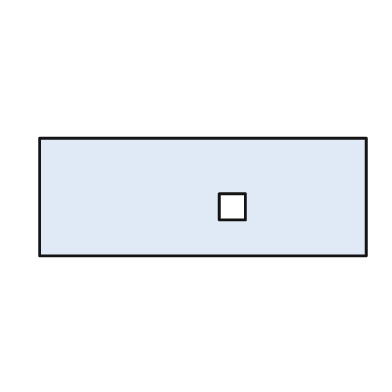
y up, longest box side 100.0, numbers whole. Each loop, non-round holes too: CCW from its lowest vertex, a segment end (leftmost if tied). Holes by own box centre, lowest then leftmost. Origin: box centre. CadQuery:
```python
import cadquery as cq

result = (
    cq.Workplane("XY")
    .moveTo(-50.0, -18.0)
    .lineTo(50.0, -18.0)
    .lineTo(50.0, 18.0)
    .lineTo(-50.0, 18.0)
    .close()
    .moveTo(5.0, -7.0)
    .lineTo(13.0, -7.0)
    .lineTo(13.0, 1.0)
    .lineTo(5.0, 1.0)
    .close()
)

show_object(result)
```